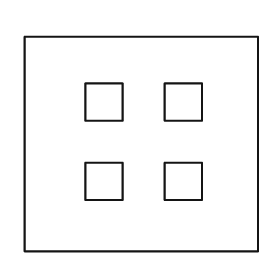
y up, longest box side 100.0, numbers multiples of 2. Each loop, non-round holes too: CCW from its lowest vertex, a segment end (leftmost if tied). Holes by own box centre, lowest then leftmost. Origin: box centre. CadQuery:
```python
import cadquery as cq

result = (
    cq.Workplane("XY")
    .moveTo(-50.0, -46.0)
    .lineTo(50.0, -46.0)
    .lineTo(50.0, 46.0)
    .lineTo(-50.0, 46.0)
    .close()
    .moveTo(-24.0, -24.0)
    .lineTo(-8.0, -24.0)
    .lineTo(-8.0, -8.0)
    .lineTo(-24.0, -8.0)
    .close()
    .moveTo(10.0, -24.0)
    .lineTo(26.0, -24.0)
    .lineTo(26.0, -8.0)
    .lineTo(10.0, -8.0)
    .close()
    .moveTo(-24.0, 10.0)
    .lineTo(-8.0, 10.0)
    .lineTo(-8.0, 26.0)
    .lineTo(-24.0, 26.0)
    .close()
    .moveTo(10.0, 10.0)
    .lineTo(26.0, 10.0)
    .lineTo(26.0, 26.0)
    .lineTo(10.0, 26.0)
    .close()
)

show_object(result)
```